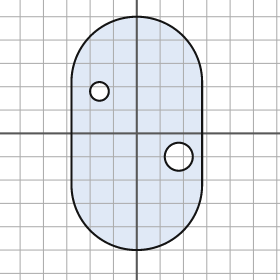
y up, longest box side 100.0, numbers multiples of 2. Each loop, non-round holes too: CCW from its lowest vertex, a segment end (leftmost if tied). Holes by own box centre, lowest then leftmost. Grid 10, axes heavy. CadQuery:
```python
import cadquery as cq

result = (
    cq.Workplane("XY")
    .moveTo(-28.0, -22.0)
    .threePointArc((0.0, -50.0), (28.0, -22.0))
    .lineTo(28.0, 22.0)
    .threePointArc((0.0, 50.0), (-28.0, 22.0))
    .close()
    .moveTo(18.0, -10.0)
    .circle(6.0)
    .moveTo(-16.0, 18.0)
    .circle(4.0)
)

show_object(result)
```